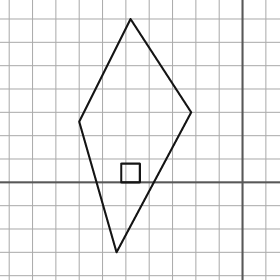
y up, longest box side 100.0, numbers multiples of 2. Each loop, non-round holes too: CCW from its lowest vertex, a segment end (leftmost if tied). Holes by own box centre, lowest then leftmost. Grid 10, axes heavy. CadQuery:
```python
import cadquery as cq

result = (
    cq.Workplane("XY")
    .moveTo(-54.0, -30.0)
    .lineTo(-22.0, 30.0)
    .lineTo(-48.0, 70.0)
    .lineTo(-70.0, 26.0)
    .close()
    .moveTo(-52.0, 0.0)
    .lineTo(-44.0, 0.0)
    .lineTo(-44.0, 8.0)
    .lineTo(-52.0, 8.0)
    .close()
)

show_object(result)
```